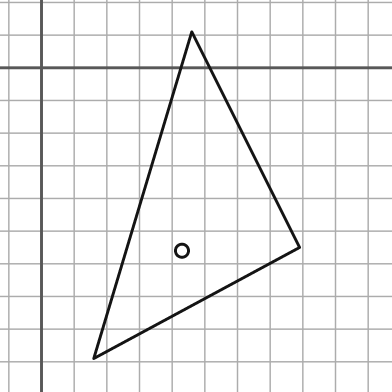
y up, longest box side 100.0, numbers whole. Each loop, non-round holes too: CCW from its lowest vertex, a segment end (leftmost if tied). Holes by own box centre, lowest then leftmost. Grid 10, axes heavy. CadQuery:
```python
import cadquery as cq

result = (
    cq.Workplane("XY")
    .moveTo(16.0, -89.0)
    .lineTo(79.0, -55.0)
    .lineTo(46.0, 11.0)
    .close()
    .moveTo(43.0, -56.0)
    .circle(2.0)
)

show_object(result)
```